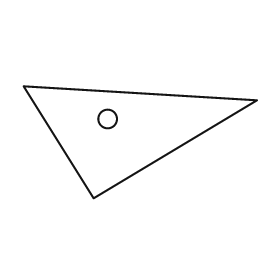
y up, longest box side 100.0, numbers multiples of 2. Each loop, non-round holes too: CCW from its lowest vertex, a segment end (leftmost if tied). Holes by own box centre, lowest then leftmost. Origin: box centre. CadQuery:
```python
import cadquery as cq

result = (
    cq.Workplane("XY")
    .moveTo(-20.0, -24.0)
    .lineTo(50.0, 18.0)
    .lineTo(-50.0, 24.0)
    .close()
    .moveTo(-14.0, 10.0)
    .circle(4.0)
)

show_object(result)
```